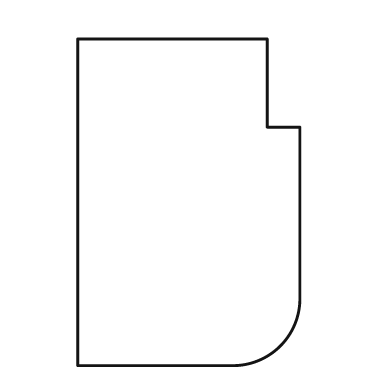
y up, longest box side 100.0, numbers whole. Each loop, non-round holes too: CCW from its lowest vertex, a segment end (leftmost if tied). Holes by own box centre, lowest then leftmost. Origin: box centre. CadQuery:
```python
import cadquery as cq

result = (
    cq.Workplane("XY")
    .moveTo(-34.0, -50.0)
    .lineTo(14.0, -50.0)
    .threePointArc((28.0, -44.0), (34.0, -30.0))
    .lineTo(34.0, 23.0)
    .lineTo(24.0, 23.0)
    .lineTo(24.0, 50.0)
    .lineTo(-34.0, 50.0)
    .close()
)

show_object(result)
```